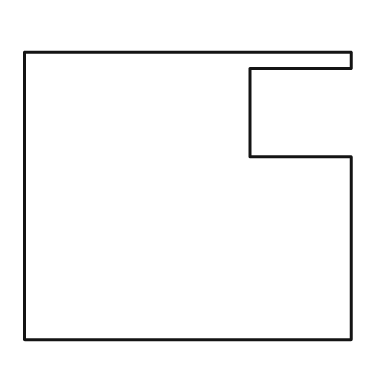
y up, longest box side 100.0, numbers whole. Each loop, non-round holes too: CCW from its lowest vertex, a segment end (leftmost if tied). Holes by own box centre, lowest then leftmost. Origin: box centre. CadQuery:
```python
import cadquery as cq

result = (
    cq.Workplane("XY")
    .moveTo(-50.0, -44.0)
    .lineTo(50.0, -44.0)
    .lineTo(50.0, 12.0)
    .lineTo(19.0, 12.0)
    .lineTo(19.0, 39.0)
    .lineTo(50.0, 39.0)
    .lineTo(50.0, 44.0)
    .lineTo(-50.0, 44.0)
    .close()
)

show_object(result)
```